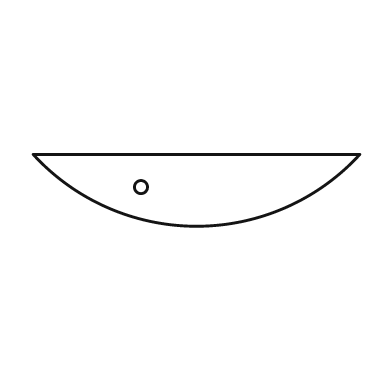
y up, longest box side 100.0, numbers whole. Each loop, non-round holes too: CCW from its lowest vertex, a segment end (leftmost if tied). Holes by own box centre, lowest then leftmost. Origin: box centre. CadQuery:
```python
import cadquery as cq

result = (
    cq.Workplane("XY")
    .moveTo(-50.0, 11.0)
    .threePointArc((0.0, -11.0), (50.0, 11.0))
    .close()
    .moveTo(-17.0, 1.0)
    .circle(2.0)
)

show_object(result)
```